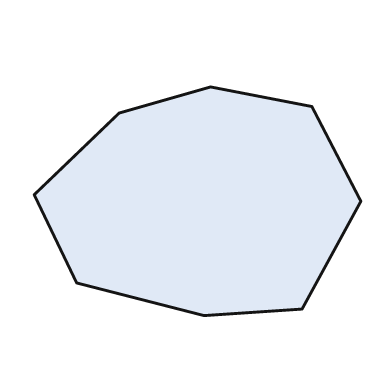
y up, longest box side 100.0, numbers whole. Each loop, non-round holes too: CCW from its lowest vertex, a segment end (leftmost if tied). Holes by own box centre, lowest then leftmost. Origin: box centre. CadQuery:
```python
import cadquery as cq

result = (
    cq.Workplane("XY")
    .moveTo(2.0, -35.0)
    .lineTo(32.0, -33.0)
    .lineTo(50.0, 0.0)
    .lineTo(35.0, 29.0)
    .lineTo(4.0, 35.0)
    .lineTo(-24.0, 27.0)
    .lineTo(-50.0, 2.0)
    .lineTo(-37.0, -25.0)
    .close()
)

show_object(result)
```